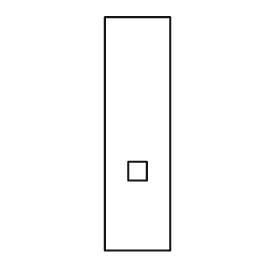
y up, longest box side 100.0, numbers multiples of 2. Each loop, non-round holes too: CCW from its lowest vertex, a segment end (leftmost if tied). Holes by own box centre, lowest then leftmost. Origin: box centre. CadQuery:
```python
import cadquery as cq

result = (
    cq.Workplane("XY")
    .moveTo(-14.0, -50.0)
    .lineTo(14.0, -50.0)
    .lineTo(14.0, 50.0)
    .lineTo(-14.0, 50.0)
    .close()
    .moveTo(-4.0, -20.0)
    .lineTo(4.0, -20.0)
    .lineTo(4.0, -12.0)
    .lineTo(-4.0, -12.0)
    .close()
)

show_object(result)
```